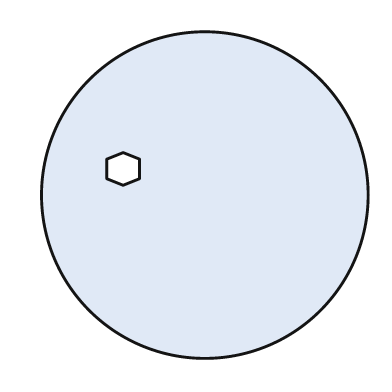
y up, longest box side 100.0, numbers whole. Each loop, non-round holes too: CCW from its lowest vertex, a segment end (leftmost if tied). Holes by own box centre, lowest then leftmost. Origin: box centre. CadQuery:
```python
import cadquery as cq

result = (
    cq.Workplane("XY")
    .moveTo(0.0, 0.0)
    .circle(50.0)
    .moveTo(-25.0, 3.0)
    .lineTo(-20.0, 5.0)
    .lineTo(-20.0, 11.0)
    .lineTo(-25.0, 13.0)
    .lineTo(-30.0, 11.0)
    .lineTo(-30.0, 5.0)
    .close()
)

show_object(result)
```